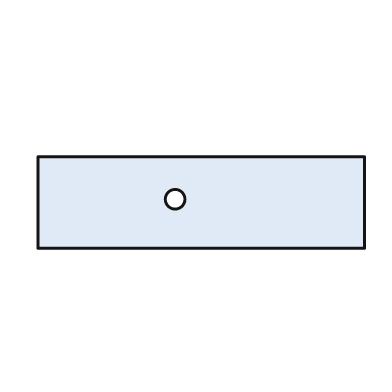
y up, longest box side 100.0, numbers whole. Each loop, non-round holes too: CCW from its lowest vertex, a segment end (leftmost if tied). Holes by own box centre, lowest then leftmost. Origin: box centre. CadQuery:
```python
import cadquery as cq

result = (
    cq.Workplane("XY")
    .moveTo(-50.0, -14.0)
    .lineTo(50.0, -14.0)
    .lineTo(50.0, 14.0)
    .lineTo(-50.0, 14.0)
    .close()
    .moveTo(-8.0, 1.0)
    .circle(3.0)
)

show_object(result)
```